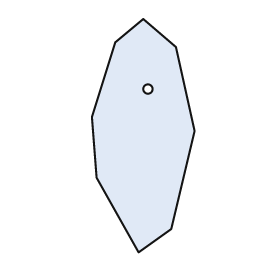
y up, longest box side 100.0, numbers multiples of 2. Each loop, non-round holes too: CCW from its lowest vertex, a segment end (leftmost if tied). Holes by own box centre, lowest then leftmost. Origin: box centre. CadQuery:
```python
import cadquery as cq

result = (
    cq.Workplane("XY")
    .moveTo(-2.0, -50.0)
    .lineTo(12.0, -40.0)
    .lineTo(22.0, 2.0)
    .lineTo(14.0, 38.0)
    .lineTo(0.0, 50.0)
    .lineTo(-12.0, 40.0)
    .lineTo(-22.0, 8.0)
    .lineTo(-20.0, -18.0)
    .close()
    .moveTo(2.0, 20.0)
    .circle(2.0)
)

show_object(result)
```